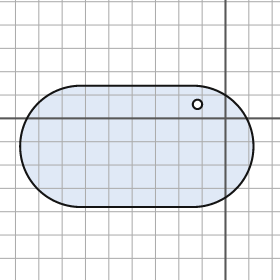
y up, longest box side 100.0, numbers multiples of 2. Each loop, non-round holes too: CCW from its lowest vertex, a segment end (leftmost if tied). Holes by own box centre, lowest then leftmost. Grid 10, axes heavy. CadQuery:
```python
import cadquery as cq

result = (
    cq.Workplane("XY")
    .moveTo(-62.0, -38.0)
    .lineTo(-14.0, -38.0)
    .threePointArc((12.0, -12.0), (-14.0, 14.0))
    .lineTo(-62.0, 14.0)
    .threePointArc((-88.0, -12.0), (-62.0, -38.0))
    .close()
    .moveTo(-12.0, 6.0)
    .circle(2.0)
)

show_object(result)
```